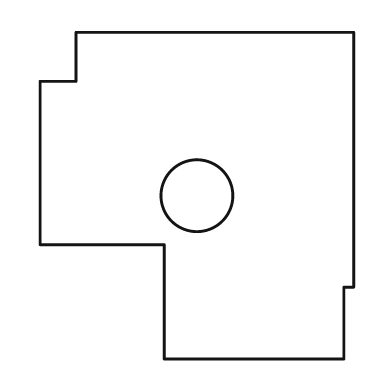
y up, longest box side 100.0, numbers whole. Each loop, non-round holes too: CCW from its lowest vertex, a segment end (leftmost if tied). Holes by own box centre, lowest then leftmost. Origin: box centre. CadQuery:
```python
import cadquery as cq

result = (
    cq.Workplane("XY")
    .moveTo(-10.0, -50.0)
    .lineTo(45.0, -50.0)
    .lineTo(45.0, -28.0)
    .lineTo(48.0, -28.0)
    .lineTo(48.0, 50.0)
    .lineTo(-37.0, 50.0)
    .lineTo(-37.0, 35.0)
    .lineTo(-48.0, 35.0)
    .lineTo(-48.0, -15.0)
    .lineTo(-10.0, -15.0)
    .close()
    .moveTo(0.0, 0.0)
    .circle(11.0)
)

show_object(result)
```